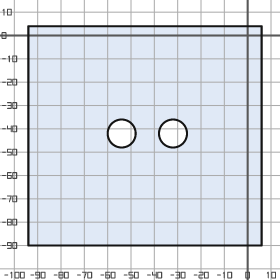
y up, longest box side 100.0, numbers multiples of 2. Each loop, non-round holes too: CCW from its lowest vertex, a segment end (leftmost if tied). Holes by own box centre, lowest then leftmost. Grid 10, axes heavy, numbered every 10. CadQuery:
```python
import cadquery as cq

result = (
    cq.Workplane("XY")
    .moveTo(-94.0, -90.0)
    .lineTo(6.0, -90.0)
    .lineTo(6.0, 4.0)
    .lineTo(-94.0, 4.0)
    .close()
    .moveTo(-54.0, -42.0)
    .circle(6.0)
    .moveTo(-32.0, -42.0)
    .circle(6.0)
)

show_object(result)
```